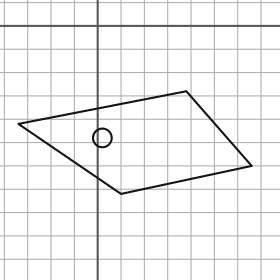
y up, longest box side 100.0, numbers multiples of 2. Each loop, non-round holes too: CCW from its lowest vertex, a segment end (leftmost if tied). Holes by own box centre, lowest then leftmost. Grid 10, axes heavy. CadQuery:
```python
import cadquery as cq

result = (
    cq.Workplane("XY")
    .moveTo(10.0, -72.0)
    .lineTo(66.0, -60.0)
    .lineTo(38.0, -28.0)
    .lineTo(-34.0, -42.0)
    .close()
    .moveTo(2.0, -48.0)
    .circle(4.0)
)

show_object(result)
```